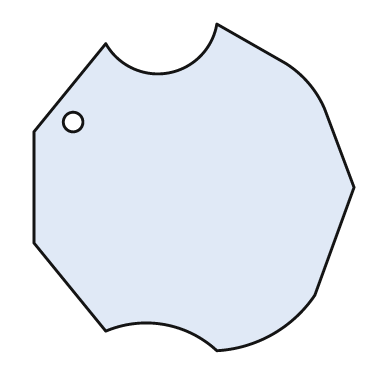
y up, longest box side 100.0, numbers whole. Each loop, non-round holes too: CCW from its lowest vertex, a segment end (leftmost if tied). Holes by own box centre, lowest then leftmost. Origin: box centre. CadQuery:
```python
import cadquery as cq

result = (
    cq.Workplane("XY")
    .moveTo(7.0, -50.0)
    .threePointArc((24.0, -45.0), (37.0, -33.0))
    .lineTo(49.0, 0.0)
    .lineTo(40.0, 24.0)
    .threePointArc((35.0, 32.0), (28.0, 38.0))
    .lineTo(7.0, 50.0)
    .threePointArc((-8.0, 35.0), (-27.0, 44.0))
    .lineTo(-49.0, 17.0)
    .lineTo(-49.0, -17.0)
    .lineTo(-27.0, -44.0)
    .threePointArc((-9.0, -42.0), (7.0, -50.0))
    .close()
    .moveTo(-37.0, 20.0)
    .circle(3.0)
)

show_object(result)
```